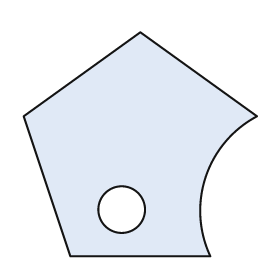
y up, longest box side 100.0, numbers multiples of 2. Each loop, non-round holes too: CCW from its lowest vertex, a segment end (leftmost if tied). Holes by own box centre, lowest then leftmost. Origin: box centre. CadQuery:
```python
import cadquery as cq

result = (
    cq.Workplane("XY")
    .moveTo(-30.0, -48.0)
    .lineTo(30.0, -48.0)
    .threePointArc((28.0, -14.0), (50.0, 12.0))
    .lineTo(0.0, 48.0)
    .lineTo(-50.0, 12.0)
    .close()
    .moveTo(-8.0, -28.0)
    .circle(10.0)
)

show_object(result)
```